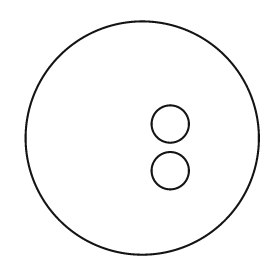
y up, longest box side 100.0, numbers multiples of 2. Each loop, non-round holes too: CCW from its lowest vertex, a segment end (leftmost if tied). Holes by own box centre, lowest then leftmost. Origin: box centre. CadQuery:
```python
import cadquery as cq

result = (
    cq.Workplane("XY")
    .moveTo(0.0, 0.0)
    .circle(50.0)
    .moveTo(12.0, -14.0)
    .circle(8.0)
    .moveTo(12.0, 6.0)
    .circle(8.0)
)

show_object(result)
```